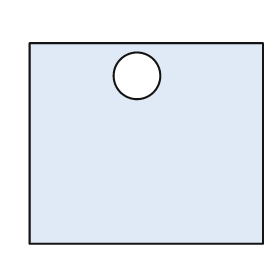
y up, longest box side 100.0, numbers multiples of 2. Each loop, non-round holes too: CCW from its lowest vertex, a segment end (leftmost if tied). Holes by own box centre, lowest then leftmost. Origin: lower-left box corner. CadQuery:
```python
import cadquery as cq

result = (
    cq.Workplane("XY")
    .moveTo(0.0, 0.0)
    .lineTo(100.0, 0.0)
    .lineTo(100.0, 86.0)
    .lineTo(0.0, 86.0)
    .close()
    .moveTo(46.0, 72.0)
    .circle(10.0)
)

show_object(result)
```